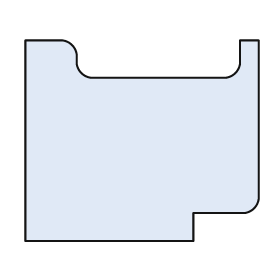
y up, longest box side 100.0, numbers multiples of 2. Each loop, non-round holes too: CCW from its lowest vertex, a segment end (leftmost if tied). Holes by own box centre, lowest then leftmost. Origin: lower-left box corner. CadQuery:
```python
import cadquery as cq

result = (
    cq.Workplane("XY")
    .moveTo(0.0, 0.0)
    .lineTo(72.0, 0.0)
    .lineTo(72.0, 12.0)
    .lineTo(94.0, 12.0)
    .threePointArc((98.0, 14.0), (100.0, 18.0))
    .lineTo(100.0, 86.0)
    .lineTo(92.0, 86.0)
    .lineTo(92.0, 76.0)
    .threePointArc((90.0, 72.0), (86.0, 70.0))
    .lineTo(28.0, 70.0)
    .threePointArc((24.0, 72.0), (22.0, 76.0))
    .lineTo(22.0, 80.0)
    .threePointArc((20.0, 84.0), (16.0, 86.0))
    .lineTo(0.0, 86.0)
    .close()
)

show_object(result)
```